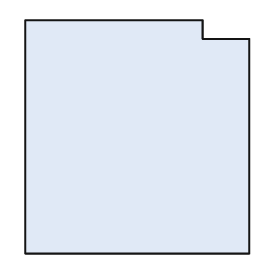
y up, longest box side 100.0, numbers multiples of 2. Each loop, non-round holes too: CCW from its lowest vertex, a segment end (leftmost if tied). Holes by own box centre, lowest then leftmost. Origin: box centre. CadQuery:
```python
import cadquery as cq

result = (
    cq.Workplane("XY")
    .moveTo(-48.0, -50.0)
    .lineTo(48.0, -50.0)
    .lineTo(48.0, 42.0)
    .lineTo(28.0, 42.0)
    .lineTo(28.0, 50.0)
    .lineTo(-48.0, 50.0)
    .close()
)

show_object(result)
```